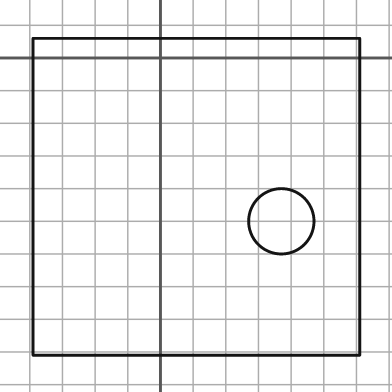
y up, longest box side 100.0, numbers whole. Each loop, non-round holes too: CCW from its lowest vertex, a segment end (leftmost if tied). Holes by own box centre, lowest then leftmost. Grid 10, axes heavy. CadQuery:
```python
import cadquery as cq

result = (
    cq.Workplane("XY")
    .moveTo(-39.0, -91.0)
    .lineTo(61.0, -91.0)
    .lineTo(61.0, 6.0)
    .lineTo(-39.0, 6.0)
    .close()
    .moveTo(37.0, -50.0)
    .circle(10.0)
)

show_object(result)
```